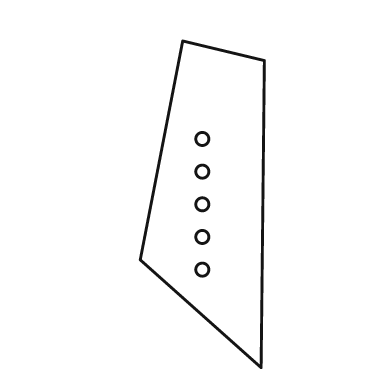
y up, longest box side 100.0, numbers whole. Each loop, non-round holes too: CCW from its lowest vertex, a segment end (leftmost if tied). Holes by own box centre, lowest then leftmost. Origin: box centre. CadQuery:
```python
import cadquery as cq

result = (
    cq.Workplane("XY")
    .moveTo(18.0, -50.0)
    .lineTo(19.0, 44.0)
    .lineTo(-6.0, 50.0)
    .lineTo(-19.0, -17.0)
    .close()
    .moveTo(0.0, -20.0)
    .circle(2.0)
    .moveTo(0.0, -10.0)
    .circle(2.0)
    .moveTo(0.0, 0.0)
    .circle(2.0)
    .moveTo(0.0, 10.0)
    .circle(2.0)
    .moveTo(0.0, 20.0)
    .circle(2.0)
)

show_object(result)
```